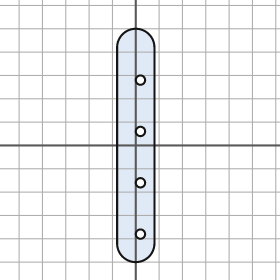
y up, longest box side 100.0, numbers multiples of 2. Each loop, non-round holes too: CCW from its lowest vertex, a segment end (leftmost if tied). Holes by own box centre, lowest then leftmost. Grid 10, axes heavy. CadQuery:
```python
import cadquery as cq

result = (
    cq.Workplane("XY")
    .moveTo(-8.0, -42.0)
    .threePointArc((0.0, -50.0), (8.0, -42.0))
    .lineTo(8.0, 42.0)
    .threePointArc((0.0, 50.0), (-8.0, 42.0))
    .close()
    .moveTo(2.0, -38.0)
    .circle(2.0)
    .moveTo(2.0, -16.0)
    .circle(2.0)
    .moveTo(2.0, 6.0)
    .circle(2.0)
    .moveTo(2.0, 28.0)
    .circle(2.0)
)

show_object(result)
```